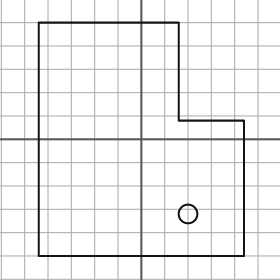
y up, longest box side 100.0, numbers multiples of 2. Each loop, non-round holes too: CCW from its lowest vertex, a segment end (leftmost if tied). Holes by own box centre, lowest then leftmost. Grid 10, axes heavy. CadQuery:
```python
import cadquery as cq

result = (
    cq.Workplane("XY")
    .moveTo(-44.0, -50.0)
    .lineTo(44.0, -50.0)
    .lineTo(44.0, 8.0)
    .lineTo(16.0, 8.0)
    .lineTo(16.0, 50.0)
    .lineTo(-44.0, 50.0)
    .close()
    .moveTo(20.0, -32.0)
    .circle(4.0)
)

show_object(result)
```